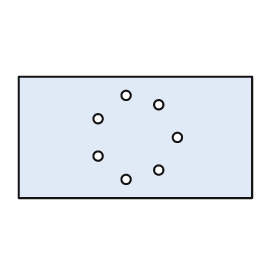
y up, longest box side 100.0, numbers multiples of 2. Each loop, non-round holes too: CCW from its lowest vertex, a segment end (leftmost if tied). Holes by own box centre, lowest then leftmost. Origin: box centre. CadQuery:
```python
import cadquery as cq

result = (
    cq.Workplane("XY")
    .moveTo(-50.0, -26.0)
    .lineTo(50.0, -26.0)
    .lineTo(50.0, 26.0)
    .lineTo(-50.0, 26.0)
    .close()
    .moveTo(-4.0, -18.0)
    .circle(2.0)
    .moveTo(10.0, -14.0)
    .circle(2.0)
    .moveTo(-16.0, -8.0)
    .circle(2.0)
    .moveTo(18.0, 0.0)
    .circle(2.0)
    .moveTo(-16.0, 8.0)
    .circle(2.0)
    .moveTo(10.0, 14.0)
    .circle(2.0)
    .moveTo(-4.0, 18.0)
    .circle(2.0)
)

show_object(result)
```